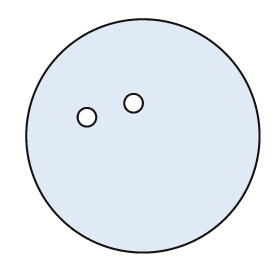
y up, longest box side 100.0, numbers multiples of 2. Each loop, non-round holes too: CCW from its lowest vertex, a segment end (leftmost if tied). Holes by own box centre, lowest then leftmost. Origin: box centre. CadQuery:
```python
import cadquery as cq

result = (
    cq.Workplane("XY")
    .moveTo(0.0, 0.0)
    .circle(50.0)
    .moveTo(-24.0, 8.0)
    .circle(4.0)
    .moveTo(-4.0, 14.0)
    .circle(4.0)
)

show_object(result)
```